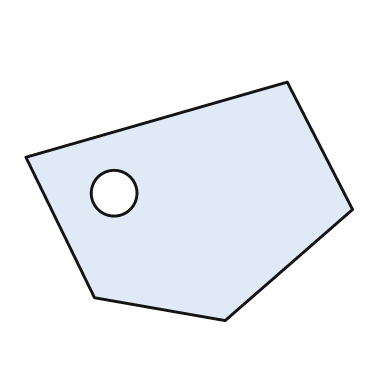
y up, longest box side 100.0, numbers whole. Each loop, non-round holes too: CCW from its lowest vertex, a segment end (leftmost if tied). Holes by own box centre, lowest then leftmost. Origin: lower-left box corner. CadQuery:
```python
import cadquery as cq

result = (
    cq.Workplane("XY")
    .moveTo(61.0, 0.0)
    .lineTo(100.0, 34.0)
    .lineTo(80.0, 73.0)
    .lineTo(0.0, 50.0)
    .lineTo(21.0, 7.0)
    .close()
    .moveTo(27.0, 39.0)
    .circle(7.0)
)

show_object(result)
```